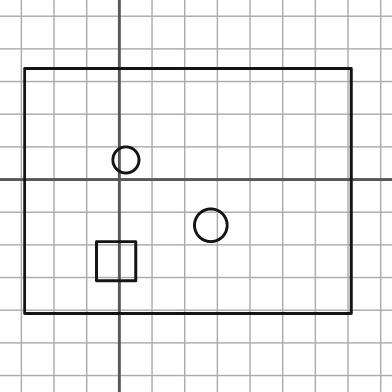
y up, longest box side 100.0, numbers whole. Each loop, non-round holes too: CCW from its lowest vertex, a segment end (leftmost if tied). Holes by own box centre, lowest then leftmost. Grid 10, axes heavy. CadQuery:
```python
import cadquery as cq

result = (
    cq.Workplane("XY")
    .moveTo(-29.0, -41.0)
    .lineTo(71.0, -41.0)
    .lineTo(71.0, 34.0)
    .lineTo(-29.0, 34.0)
    .close()
    .moveTo(-7.0, -31.0)
    .lineTo(5.0, -31.0)
    .lineTo(5.0, -19.0)
    .lineTo(-7.0, -19.0)
    .close()
    .moveTo(28.0, -14.0)
    .circle(5.0)
    .moveTo(2.0, 6.0)
    .circle(4.0)
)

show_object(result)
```